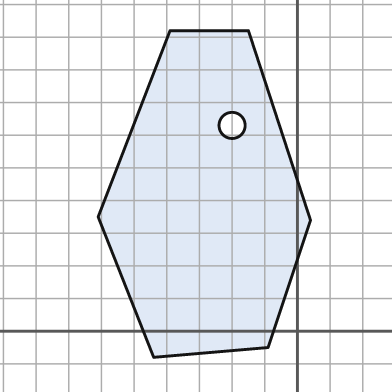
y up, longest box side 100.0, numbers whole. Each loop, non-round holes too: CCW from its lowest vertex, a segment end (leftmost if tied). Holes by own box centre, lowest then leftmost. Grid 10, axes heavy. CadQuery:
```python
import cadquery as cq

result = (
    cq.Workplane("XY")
    .moveTo(-44.0, -8.0)
    .lineTo(-9.0, -5.0)
    .lineTo(4.0, 34.0)
    .lineTo(-15.0, 92.0)
    .lineTo(-39.0, 92.0)
    .lineTo(-61.0, 35.0)
    .close()
    .moveTo(-20.0, 63.0)
    .circle(4.0)
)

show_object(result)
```